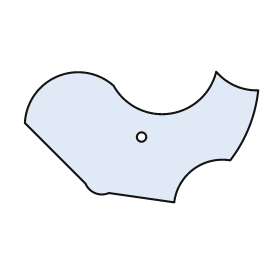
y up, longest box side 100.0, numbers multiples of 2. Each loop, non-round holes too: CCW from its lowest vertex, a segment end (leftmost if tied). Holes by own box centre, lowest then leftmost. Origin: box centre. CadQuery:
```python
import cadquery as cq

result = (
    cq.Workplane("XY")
    .moveTo(14.0, -28.0)
    .threePointArc((22.0, -14.0), (38.0, -10.0))
    .threePointArc((46.0, 4.0), (50.0, 20.0))
    .threePointArc((40.0, 22.0), (32.0, 28.0))
    .threePointArc((12.0, 10.0), (-12.0, 22.0))
    .threePointArc((-36.0, 26.0), (-50.0, 6.0))
    .lineTo(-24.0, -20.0)
    .threePointArc((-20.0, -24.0), (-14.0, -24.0))
    .close()
    .moveTo(0.0, 0.0)
    .circle(2.0)
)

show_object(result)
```